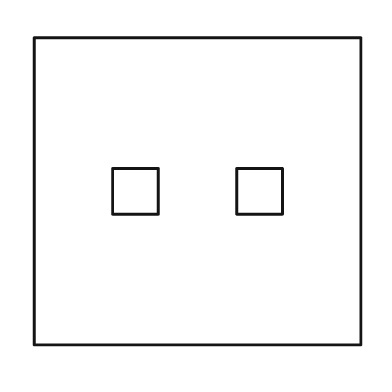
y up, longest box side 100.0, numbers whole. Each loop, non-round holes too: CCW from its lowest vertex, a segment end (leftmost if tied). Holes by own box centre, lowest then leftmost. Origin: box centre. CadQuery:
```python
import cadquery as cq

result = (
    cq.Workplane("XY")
    .moveTo(-50.0, -47.0)
    .lineTo(50.0, -47.0)
    .lineTo(50.0, 47.0)
    .lineTo(-50.0, 47.0)
    .close()
    .moveTo(-26.0, -7.0)
    .lineTo(-12.0, -7.0)
    .lineTo(-12.0, 7.0)
    .lineTo(-26.0, 7.0)
    .close()
    .moveTo(12.0, -7.0)
    .lineTo(26.0, -7.0)
    .lineTo(26.0, 7.0)
    .lineTo(12.0, 7.0)
    .close()
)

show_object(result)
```